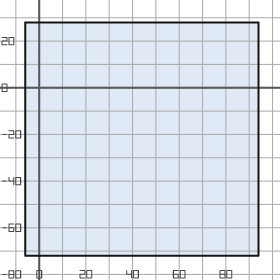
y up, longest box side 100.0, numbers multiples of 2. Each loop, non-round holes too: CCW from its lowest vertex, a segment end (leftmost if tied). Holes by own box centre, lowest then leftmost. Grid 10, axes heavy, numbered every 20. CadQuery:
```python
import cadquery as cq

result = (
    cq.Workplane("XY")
    .moveTo(-6.0, -72.0)
    .lineTo(94.0, -72.0)
    .lineTo(94.0, 28.0)
    .lineTo(-6.0, 28.0)
    .close()
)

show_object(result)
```